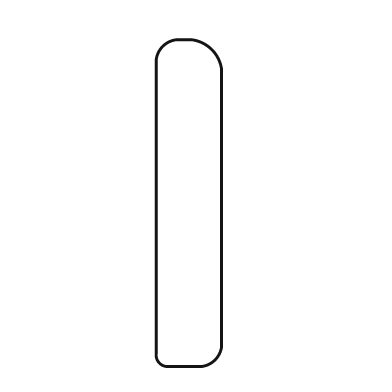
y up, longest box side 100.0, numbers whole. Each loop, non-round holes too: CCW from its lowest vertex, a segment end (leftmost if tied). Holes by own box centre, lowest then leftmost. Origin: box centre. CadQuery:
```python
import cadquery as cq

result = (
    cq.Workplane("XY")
    .moveTo(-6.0, -50.0)
    .lineTo(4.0, -50.0)
    .threePointArc((8.0, -48.0), (10.0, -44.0))
    .lineTo(10.0, 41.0)
    .threePointArc((7.0, 47.0), (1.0, 50.0))
    .lineTo(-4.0, 50.0)
    .threePointArc((-8.0, 48.0), (-10.0, 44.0))
    .lineTo(-10.0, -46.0)
    .threePointArc((-9.0, -49.0), (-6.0, -50.0))
    .close()
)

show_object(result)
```